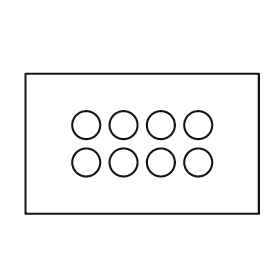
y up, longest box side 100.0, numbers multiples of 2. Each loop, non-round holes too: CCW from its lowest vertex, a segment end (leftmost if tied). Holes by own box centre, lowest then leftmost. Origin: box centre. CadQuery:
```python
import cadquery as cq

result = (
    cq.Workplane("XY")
    .moveTo(-50.0, -30.0)
    .lineTo(50.0, -30.0)
    .lineTo(50.0, 30.0)
    .lineTo(-50.0, 30.0)
    .close()
    .moveTo(-24.0, -8.0)
    .circle(6.0)
    .moveTo(-8.0, -8.0)
    .circle(6.0)
    .moveTo(8.0, -8.0)
    .circle(6.0)
    .moveTo(24.0, -8.0)
    .circle(6.0)
    .moveTo(-24.0, 8.0)
    .circle(6.0)
    .moveTo(-8.0, 8.0)
    .circle(6.0)
    .moveTo(8.0, 8.0)
    .circle(6.0)
    .moveTo(24.0, 8.0)
    .circle(6.0)
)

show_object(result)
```